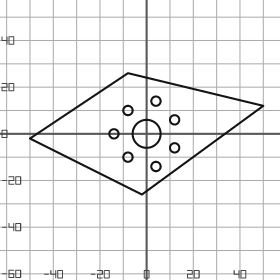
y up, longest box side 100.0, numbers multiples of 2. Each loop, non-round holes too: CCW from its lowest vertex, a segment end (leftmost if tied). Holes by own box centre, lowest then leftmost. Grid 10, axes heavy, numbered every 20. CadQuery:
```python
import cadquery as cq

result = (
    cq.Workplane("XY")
    .moveTo(-2.0, -26.0)
    .lineTo(50.0, 12.0)
    .lineTo(-8.0, 26.0)
    .lineTo(-50.0, -2.0)
    .close()
    .moveTo(4.0, -14.0)
    .circle(2.0)
    .moveTo(-8.0, -10.0)
    .circle(2.0)
    .moveTo(12.0, -6.0)
    .circle(2.0)
    .moveTo(-14.0, 0.0)
    .circle(2.0)
    .moveTo(0.0, 0.0)
    .circle(6.0)
    .moveTo(12.0, 6.0)
    .circle(2.0)
    .moveTo(-8.0, 10.0)
    .circle(2.0)
    .moveTo(4.0, 14.0)
    .circle(2.0)
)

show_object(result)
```